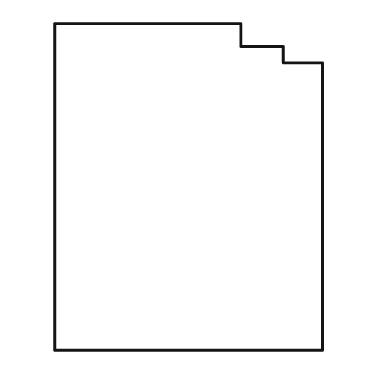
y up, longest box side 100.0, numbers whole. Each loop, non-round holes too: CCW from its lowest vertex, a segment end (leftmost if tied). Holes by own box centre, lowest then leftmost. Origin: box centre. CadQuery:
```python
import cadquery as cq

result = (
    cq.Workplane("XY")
    .moveTo(-41.0, -50.0)
    .lineTo(41.0, -50.0)
    .lineTo(41.0, 38.0)
    .lineTo(29.0, 38.0)
    .lineTo(29.0, 43.0)
    .lineTo(16.0, 43.0)
    .lineTo(16.0, 50.0)
    .lineTo(-41.0, 50.0)
    .close()
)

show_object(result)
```